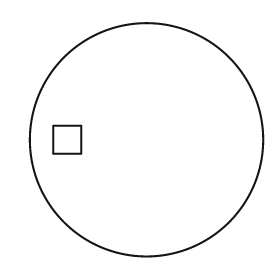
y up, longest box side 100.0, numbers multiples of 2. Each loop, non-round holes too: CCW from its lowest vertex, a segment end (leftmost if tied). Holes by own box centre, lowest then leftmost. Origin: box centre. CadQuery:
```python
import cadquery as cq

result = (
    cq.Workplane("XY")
    .moveTo(0.0, 0.0)
    .circle(50.0)
    .moveTo(-40.0, -6.0)
    .lineTo(-28.0, -6.0)
    .lineTo(-28.0, 6.0)
    .lineTo(-40.0, 6.0)
    .close()
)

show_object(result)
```